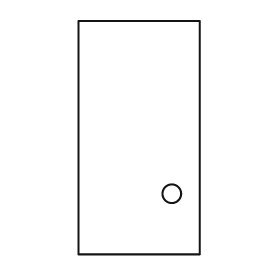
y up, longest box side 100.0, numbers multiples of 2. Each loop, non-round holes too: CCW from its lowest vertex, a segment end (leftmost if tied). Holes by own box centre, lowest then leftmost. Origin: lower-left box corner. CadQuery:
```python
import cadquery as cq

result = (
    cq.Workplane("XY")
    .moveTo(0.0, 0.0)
    .lineTo(52.0, 0.0)
    .lineTo(52.0, 100.0)
    .lineTo(0.0, 100.0)
    .close()
    .moveTo(40.0, 26.0)
    .circle(4.0)
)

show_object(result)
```